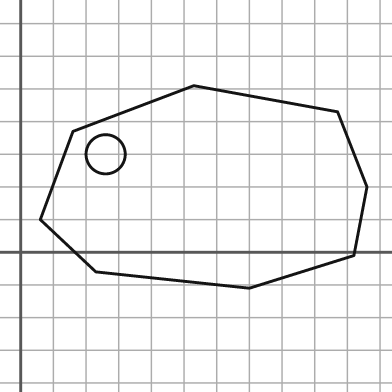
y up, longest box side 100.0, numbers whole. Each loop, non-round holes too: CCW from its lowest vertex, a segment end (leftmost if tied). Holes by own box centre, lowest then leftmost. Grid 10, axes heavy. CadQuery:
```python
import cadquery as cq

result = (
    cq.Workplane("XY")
    .moveTo(70.0, -11.0)
    .lineTo(102.0, -1.0)
    .lineTo(106.0, 20.0)
    .lineTo(97.0, 43.0)
    .lineTo(53.0, 51.0)
    .lineTo(16.0, 37.0)
    .lineTo(6.0, 10.0)
    .lineTo(23.0, -6.0)
    .close()
    .moveTo(26.0, 30.0)
    .circle(6.0)
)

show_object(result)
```